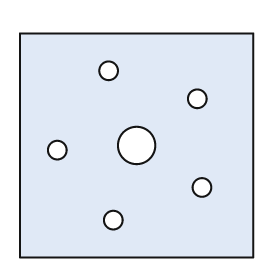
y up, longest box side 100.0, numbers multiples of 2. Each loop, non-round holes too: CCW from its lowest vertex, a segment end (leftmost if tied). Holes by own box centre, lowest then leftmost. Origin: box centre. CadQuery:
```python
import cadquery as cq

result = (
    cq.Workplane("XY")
    .moveTo(-50.0, -48.0)
    .lineTo(50.0, -48.0)
    .lineTo(50.0, 48.0)
    .lineTo(-50.0, 48.0)
    .close()
    .moveTo(-10.0, -32.0)
    .circle(4.0)
    .moveTo(28.0, -18.0)
    .circle(4.0)
    .moveTo(-34.0, -2.0)
    .circle(4.0)
    .moveTo(0.0, 0.0)
    .circle(8.0)
    .moveTo(26.0, 20.0)
    .circle(4.0)
    .moveTo(-12.0, 32.0)
    .circle(4.0)
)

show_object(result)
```